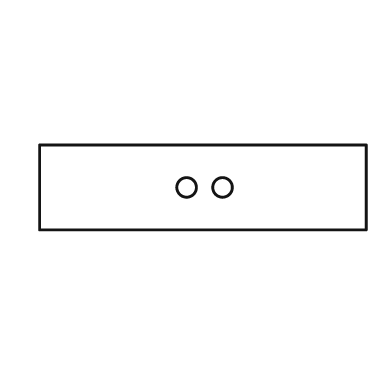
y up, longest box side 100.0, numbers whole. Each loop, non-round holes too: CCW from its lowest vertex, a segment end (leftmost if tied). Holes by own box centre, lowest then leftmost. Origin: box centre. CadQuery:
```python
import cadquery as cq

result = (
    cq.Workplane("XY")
    .moveTo(-50.0, -13.0)
    .lineTo(50.0, -13.0)
    .lineTo(50.0, 13.0)
    .lineTo(-50.0, 13.0)
    .close()
    .moveTo(-5.0, 0.0)
    .circle(3.0)
    .moveTo(6.0, 0.0)
    .circle(3.0)
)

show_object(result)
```